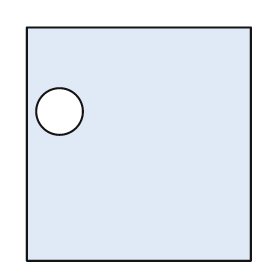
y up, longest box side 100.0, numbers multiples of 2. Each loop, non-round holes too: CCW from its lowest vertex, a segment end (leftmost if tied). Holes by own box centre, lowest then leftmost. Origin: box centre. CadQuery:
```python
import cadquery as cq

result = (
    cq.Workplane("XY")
    .moveTo(-48.0, -50.0)
    .lineTo(48.0, -50.0)
    .lineTo(48.0, 50.0)
    .lineTo(-48.0, 50.0)
    .close()
    .moveTo(-34.0, 14.0)
    .circle(10.0)
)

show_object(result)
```